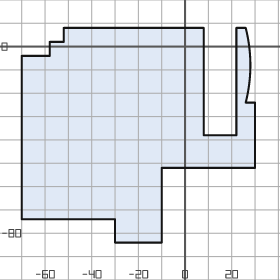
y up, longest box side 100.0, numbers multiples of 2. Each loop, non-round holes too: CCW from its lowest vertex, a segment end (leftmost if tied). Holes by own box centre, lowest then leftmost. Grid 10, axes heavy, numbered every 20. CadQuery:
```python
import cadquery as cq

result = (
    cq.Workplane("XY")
    .moveTo(-30.0, -84.0)
    .lineTo(-10.0, -84.0)
    .lineTo(-10.0, -52.0)
    .lineTo(30.0, -52.0)
    .lineTo(30.0, -24.0)
    .lineTo(26.0, -24.0)
    .threePointArc((28.0, -8.0), (26.0, 8.0))
    .lineTo(22.0, 8.0)
    .lineTo(22.0, -38.0)
    .lineTo(8.0, -38.0)
    .lineTo(8.0, 8.0)
    .lineTo(-52.0, 8.0)
    .lineTo(-52.0, 2.0)
    .lineTo(-58.0, 2.0)
    .lineTo(-58.0, -4.0)
    .lineTo(-70.0, -4.0)
    .lineTo(-70.0, -74.0)
    .lineTo(-30.0, -74.0)
    .close()
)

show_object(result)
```